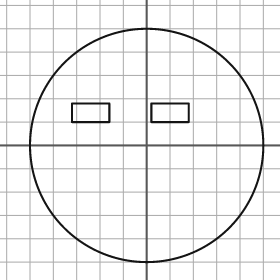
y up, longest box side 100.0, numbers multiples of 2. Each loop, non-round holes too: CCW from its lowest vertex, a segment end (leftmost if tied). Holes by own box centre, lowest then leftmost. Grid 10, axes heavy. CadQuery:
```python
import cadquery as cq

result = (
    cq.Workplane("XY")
    .moveTo(0.0, 0.0)
    .circle(50.0)
    .moveTo(-32.0, 10.0)
    .lineTo(-16.0, 10.0)
    .lineTo(-16.0, 18.0)
    .lineTo(-32.0, 18.0)
    .close()
    .moveTo(2.0, 10.0)
    .lineTo(18.0, 10.0)
    .lineTo(18.0, 18.0)
    .lineTo(2.0, 18.0)
    .close()
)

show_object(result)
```